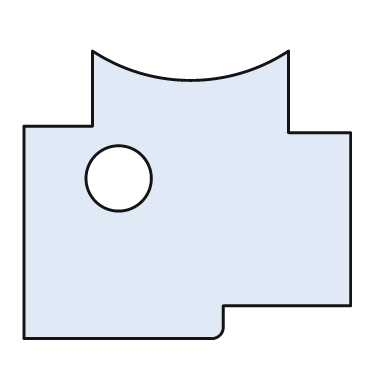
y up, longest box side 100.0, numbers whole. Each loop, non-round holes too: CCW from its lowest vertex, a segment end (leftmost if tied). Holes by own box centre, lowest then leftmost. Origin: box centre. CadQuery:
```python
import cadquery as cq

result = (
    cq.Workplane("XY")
    .moveTo(-50.0, -44.0)
    .lineTo(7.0, -44.0)
    .threePointArc((10.0, -43.0), (11.0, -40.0))
    .lineTo(11.0, -34.0)
    .lineTo(50.0, -34.0)
    .lineTo(50.0, 19.0)
    .lineTo(31.0, 19.0)
    .lineTo(31.0, 44.0)
    .threePointArc((1.0, 35.0), (-29.0, 44.0))
    .lineTo(-29.0, 21.0)
    .lineTo(-50.0, 21.0)
    .close()
    .moveTo(-21.0, 5.0)
    .circle(10.0)
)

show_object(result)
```